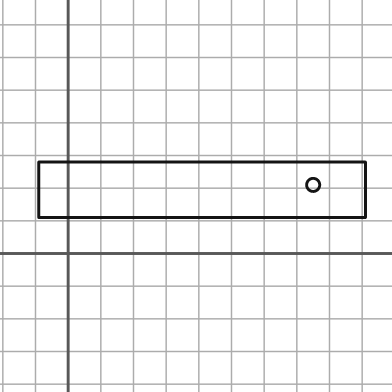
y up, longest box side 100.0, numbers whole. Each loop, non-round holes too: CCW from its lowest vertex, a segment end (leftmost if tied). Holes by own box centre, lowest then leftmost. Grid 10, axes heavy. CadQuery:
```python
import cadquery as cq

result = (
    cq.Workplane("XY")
    .moveTo(-9.0, 11.0)
    .lineTo(91.0, 11.0)
    .lineTo(91.0, 28.0)
    .lineTo(-9.0, 28.0)
    .close()
    .moveTo(75.0, 21.0)
    .circle(2.0)
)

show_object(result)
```